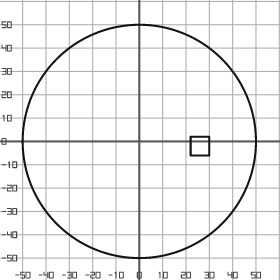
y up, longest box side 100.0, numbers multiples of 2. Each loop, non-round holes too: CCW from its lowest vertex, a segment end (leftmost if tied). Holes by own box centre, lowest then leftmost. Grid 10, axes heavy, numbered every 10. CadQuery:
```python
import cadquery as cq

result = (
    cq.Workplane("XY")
    .moveTo(0.0, 0.0)
    .circle(50.0)
    .moveTo(22.0, -6.0)
    .lineTo(30.0, -6.0)
    .lineTo(30.0, 2.0)
    .lineTo(22.0, 2.0)
    .close()
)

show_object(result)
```